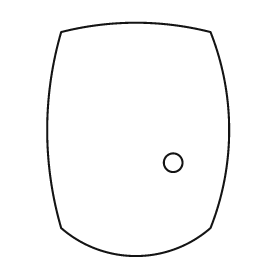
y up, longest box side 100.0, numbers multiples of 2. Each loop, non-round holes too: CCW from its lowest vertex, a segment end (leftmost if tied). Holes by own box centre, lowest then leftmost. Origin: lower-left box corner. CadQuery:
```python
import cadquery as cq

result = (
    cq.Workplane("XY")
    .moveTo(6.0, 12.0)
    .threePointArc((38.0, 0.0), (70.0, 12.0))
    .threePointArc((78.0, 54.0), (70.0, 96.0))
    .threePointArc((38.0, 100.0), (6.0, 96.0))
    .threePointArc((0.0, 54.0), (6.0, 12.0))
    .close()
    .moveTo(54.0, 40.0)
    .circle(4.0)
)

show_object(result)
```